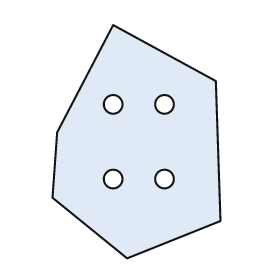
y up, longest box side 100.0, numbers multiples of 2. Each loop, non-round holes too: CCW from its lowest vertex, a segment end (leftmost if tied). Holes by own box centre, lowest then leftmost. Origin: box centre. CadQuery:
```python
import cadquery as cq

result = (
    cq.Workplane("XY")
    .moveTo(-4.0, -50.0)
    .lineTo(36.0, -34.0)
    .lineTo(34.0, 26.0)
    .lineTo(-10.0, 50.0)
    .lineTo(-34.0, 4.0)
    .lineTo(-36.0, -24.0)
    .close()
    .moveTo(-10.0, -16.0)
    .circle(4.0)
    .moveTo(12.0, -16.0)
    .circle(4.0)
    .moveTo(-10.0, 16.0)
    .circle(4.0)
    .moveTo(12.0, 16.0)
    .circle(4.0)
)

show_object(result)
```